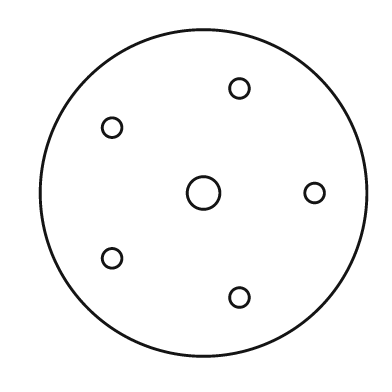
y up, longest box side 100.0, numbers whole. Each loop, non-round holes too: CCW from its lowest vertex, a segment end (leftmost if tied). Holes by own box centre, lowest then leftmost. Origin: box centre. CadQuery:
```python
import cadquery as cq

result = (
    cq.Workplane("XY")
    .moveTo(0.0, 0.0)
    .circle(50.0)
    .moveTo(11.0, -32.0)
    .circle(3.0)
    .moveTo(-28.0, -20.0)
    .circle(3.0)
    .moveTo(0.0, 0.0)
    .circle(5.0)
    .moveTo(34.0, 0.0)
    .circle(3.0)
    .moveTo(-28.0, 20.0)
    .circle(3.0)
    .moveTo(11.0, 32.0)
    .circle(3.0)
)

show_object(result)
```